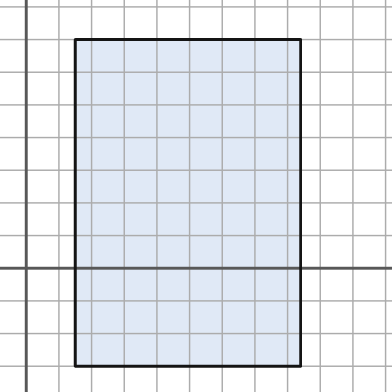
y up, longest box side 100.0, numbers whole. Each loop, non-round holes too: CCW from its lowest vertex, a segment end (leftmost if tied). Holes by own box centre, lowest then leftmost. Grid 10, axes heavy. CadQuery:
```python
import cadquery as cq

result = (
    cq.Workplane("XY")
    .moveTo(15.0, -30.0)
    .lineTo(84.0, -30.0)
    .lineTo(84.0, 70.0)
    .lineTo(15.0, 70.0)
    .close()
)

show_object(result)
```